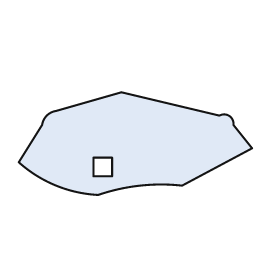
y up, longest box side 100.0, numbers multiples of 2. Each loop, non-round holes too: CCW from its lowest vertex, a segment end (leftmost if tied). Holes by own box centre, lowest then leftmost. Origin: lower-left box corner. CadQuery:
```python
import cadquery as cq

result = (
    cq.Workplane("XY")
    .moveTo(34.0, 0.0)
    .threePointArc((52.0, 4.0), (70.0, 4.0))
    .lineTo(100.0, 20.0)
    .lineTo(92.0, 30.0)
    .threePointArc((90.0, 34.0), (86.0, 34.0))
    .lineTo(44.0, 44.0)
    .lineTo(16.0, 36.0)
    .threePointArc((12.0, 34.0), (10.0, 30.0))
    .lineTo(0.0, 14.0)
    .threePointArc((16.0, 4.0), (34.0, 0.0))
    .close()
    .moveTo(32.0, 8.0)
    .lineTo(40.0, 8.0)
    .lineTo(40.0, 16.0)
    .lineTo(32.0, 16.0)
    .close()
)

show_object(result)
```